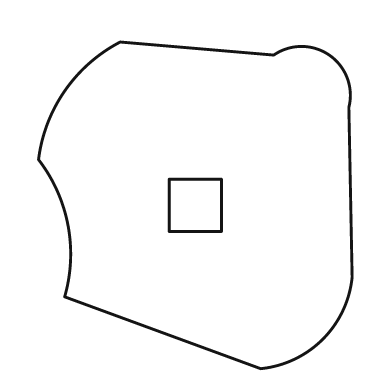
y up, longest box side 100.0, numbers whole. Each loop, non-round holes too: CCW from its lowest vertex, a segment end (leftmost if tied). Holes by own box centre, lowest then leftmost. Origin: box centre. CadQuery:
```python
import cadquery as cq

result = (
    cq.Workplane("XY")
    .moveTo(20.0, -50.0)
    .threePointArc((39.0, -41.0), (48.0, -22.0))
    .lineTo(47.0, 30.0)
    .threePointArc((41.0, 46.0), (24.0, 46.0))
    .lineTo(-23.0, 50.0)
    .threePointArc((-40.0, 35.0), (-48.0, 14.0))
    .threePointArc((-39.0, -6.0), (-40.0, -28.0))
    .close()
    .moveTo(-8.0, -8.0)
    .lineTo(8.0, -8.0)
    .lineTo(8.0, 8.0)
    .lineTo(-8.0, 8.0)
    .close()
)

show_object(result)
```